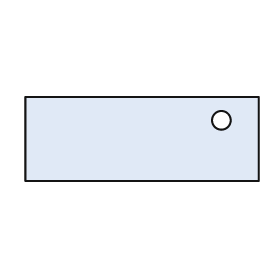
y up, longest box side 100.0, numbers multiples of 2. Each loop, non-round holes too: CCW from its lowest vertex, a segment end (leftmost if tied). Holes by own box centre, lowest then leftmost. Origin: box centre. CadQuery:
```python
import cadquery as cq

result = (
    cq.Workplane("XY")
    .moveTo(-50.0, -18.0)
    .lineTo(50.0, -18.0)
    .lineTo(50.0, 18.0)
    .lineTo(-50.0, 18.0)
    .close()
    .moveTo(34.0, 8.0)
    .circle(4.0)
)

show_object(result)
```